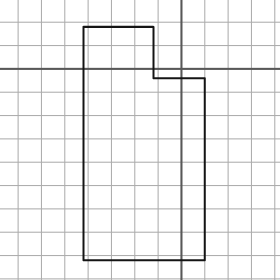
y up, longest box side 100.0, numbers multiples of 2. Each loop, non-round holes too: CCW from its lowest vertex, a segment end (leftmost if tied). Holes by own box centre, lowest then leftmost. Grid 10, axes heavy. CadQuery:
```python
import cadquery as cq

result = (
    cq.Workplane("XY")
    .moveTo(-42.0, -82.0)
    .lineTo(10.0, -82.0)
    .lineTo(10.0, -4.0)
    .lineTo(-12.0, -4.0)
    .lineTo(-12.0, 18.0)
    .lineTo(-42.0, 18.0)
    .close()
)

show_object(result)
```